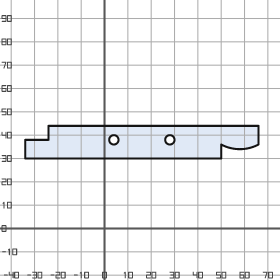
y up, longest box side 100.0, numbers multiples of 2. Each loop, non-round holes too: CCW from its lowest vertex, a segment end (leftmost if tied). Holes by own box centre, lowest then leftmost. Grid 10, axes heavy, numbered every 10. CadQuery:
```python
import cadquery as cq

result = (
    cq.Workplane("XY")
    .moveTo(-34.0, 30.0)
    .lineTo(50.0, 30.0)
    .lineTo(50.0, 36.0)
    .threePointArc((58.0, 34.0), (66.0, 36.0))
    .lineTo(66.0, 44.0)
    .lineTo(-24.0, 44.0)
    .lineTo(-24.0, 38.0)
    .lineTo(-34.0, 38.0)
    .close()
    .moveTo(4.0, 38.0)
    .circle(2.0)
    .moveTo(28.0, 38.0)
    .circle(2.0)
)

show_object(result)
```